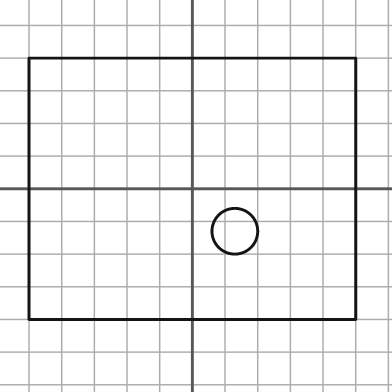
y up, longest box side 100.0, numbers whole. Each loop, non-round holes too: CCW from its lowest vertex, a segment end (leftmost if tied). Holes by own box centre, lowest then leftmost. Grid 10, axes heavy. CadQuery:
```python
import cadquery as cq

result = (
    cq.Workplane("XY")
    .moveTo(-50.0, -40.0)
    .lineTo(50.0, -40.0)
    .lineTo(50.0, 40.0)
    .lineTo(-50.0, 40.0)
    .close()
    .moveTo(13.0, -13.0)
    .circle(7.0)
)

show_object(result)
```